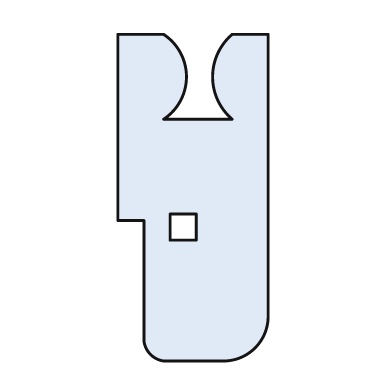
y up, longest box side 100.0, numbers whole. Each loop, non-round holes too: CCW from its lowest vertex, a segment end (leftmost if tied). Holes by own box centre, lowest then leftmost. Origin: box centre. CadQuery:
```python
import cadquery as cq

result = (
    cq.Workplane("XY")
    .moveTo(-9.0, -50.0)
    .lineTo(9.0, -50.0)
    .threePointArc((19.0, -46.0), (23.0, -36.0))
    .lineTo(23.0, 50.0)
    .lineTo(12.0, 50.0)
    .threePointArc((6.0, 37.0), (12.0, 24.0))
    .lineTo(-9.0, 24.0)
    .threePointArc((-2.0, 37.0), (-9.0, 50.0))
    .lineTo(-23.0, 50.0)
    .lineTo(-23.0, -7.0)
    .lineTo(-15.0, -7.0)
    .lineTo(-15.0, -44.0)
    .threePointArc((-13.0, -48.0), (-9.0, -50.0))
    .close()
    .moveTo(-7.0, -13.0)
    .lineTo(1.0, -13.0)
    .lineTo(1.0, -5.0)
    .lineTo(-7.0, -5.0)
    .close()
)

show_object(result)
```